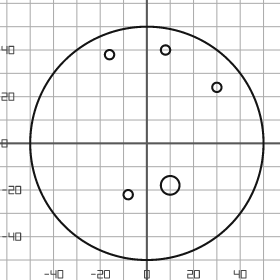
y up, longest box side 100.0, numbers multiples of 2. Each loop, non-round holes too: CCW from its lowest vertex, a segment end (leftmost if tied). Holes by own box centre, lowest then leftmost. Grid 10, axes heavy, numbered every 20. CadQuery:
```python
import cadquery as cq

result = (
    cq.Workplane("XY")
    .moveTo(0.0, 0.0)
    .circle(50.0)
    .moveTo(-8.0, -22.0)
    .circle(2.0)
    .moveTo(10.0, -18.0)
    .circle(4.0)
    .moveTo(30.0, 24.0)
    .circle(2.0)
    .moveTo(-16.0, 38.0)
    .circle(2.0)
    .moveTo(8.0, 40.0)
    .circle(2.0)
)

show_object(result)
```